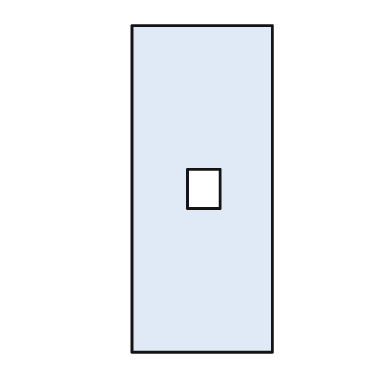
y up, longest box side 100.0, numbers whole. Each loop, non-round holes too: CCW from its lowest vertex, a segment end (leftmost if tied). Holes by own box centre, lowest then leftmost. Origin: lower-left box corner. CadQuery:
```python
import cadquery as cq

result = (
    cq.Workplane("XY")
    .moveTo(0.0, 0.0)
    .lineTo(43.0, 0.0)
    .lineTo(43.0, 100.0)
    .lineTo(0.0, 100.0)
    .close()
    .moveTo(17.0, 44.0)
    .lineTo(27.0, 44.0)
    .lineTo(27.0, 56.0)
    .lineTo(17.0, 56.0)
    .close()
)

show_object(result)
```